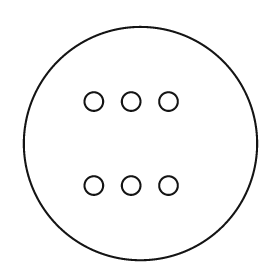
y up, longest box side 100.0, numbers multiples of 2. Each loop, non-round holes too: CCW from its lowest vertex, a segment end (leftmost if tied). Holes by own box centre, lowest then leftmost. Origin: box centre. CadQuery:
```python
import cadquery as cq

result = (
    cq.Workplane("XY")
    .moveTo(0.0, 0.0)
    .circle(50.0)
    .moveTo(-20.0, -18.0)
    .circle(4.0)
    .moveTo(-4.0, -18.0)
    .circle(4.0)
    .moveTo(12.0, -18.0)
    .circle(4.0)
    .moveTo(-20.0, 18.0)
    .circle(4.0)
    .moveTo(-4.0, 18.0)
    .circle(4.0)
    .moveTo(12.0, 18.0)
    .circle(4.0)
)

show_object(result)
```